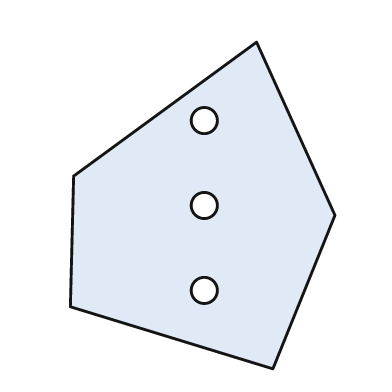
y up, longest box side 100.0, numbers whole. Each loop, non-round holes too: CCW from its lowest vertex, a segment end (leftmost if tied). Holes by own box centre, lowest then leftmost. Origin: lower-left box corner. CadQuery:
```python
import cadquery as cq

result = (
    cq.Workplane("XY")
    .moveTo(62.0, 0.0)
    .lineTo(81.0, 47.0)
    .lineTo(57.0, 100.0)
    .lineTo(1.0, 59.0)
    .lineTo(0.0, 19.0)
    .close()
    .moveTo(41.0, 24.0)
    .circle(4.0)
    .moveTo(41.0, 50.0)
    .circle(4.0)
    .moveTo(41.0, 76.0)
    .circle(4.0)
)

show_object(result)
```